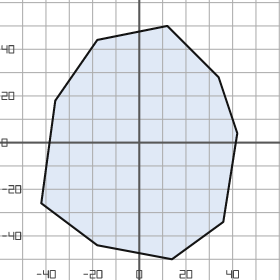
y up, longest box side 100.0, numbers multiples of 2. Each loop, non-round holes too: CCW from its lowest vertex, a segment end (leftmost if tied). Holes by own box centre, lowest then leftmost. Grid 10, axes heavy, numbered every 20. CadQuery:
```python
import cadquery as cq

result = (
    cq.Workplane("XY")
    .moveTo(14.0, -50.0)
    .lineTo(36.0, -34.0)
    .lineTo(42.0, 4.0)
    .lineTo(34.0, 28.0)
    .lineTo(12.0, 50.0)
    .lineTo(-18.0, 44.0)
    .lineTo(-36.0, 18.0)
    .lineTo(-42.0, -26.0)
    .lineTo(-18.0, -44.0)
    .close()
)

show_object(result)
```